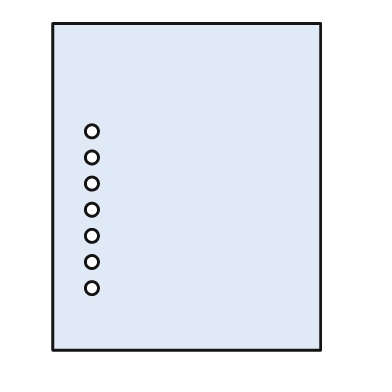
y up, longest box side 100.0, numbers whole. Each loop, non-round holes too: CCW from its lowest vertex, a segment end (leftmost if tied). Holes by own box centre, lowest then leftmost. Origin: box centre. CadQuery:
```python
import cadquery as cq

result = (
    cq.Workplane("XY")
    .moveTo(-41.0, -50.0)
    .lineTo(41.0, -50.0)
    .lineTo(41.0, 50.0)
    .lineTo(-41.0, 50.0)
    .close()
    .moveTo(-29.0, -31.0)
    .circle(2.0)
    .moveTo(-29.0, -23.0)
    .circle(2.0)
    .moveTo(-29.0, -15.0)
    .circle(2.0)
    .moveTo(-29.0, -7.0)
    .circle(2.0)
    .moveTo(-29.0, 1.0)
    .circle(2.0)
    .moveTo(-29.0, 9.0)
    .circle(2.0)
    .moveTo(-29.0, 17.0)
    .circle(2.0)
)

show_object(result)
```